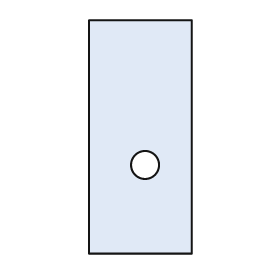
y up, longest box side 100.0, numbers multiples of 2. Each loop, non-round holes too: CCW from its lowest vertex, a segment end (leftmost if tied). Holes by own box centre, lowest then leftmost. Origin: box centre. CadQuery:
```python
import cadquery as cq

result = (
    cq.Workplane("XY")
    .moveTo(-22.0, -50.0)
    .lineTo(22.0, -50.0)
    .lineTo(22.0, 50.0)
    .lineTo(-22.0, 50.0)
    .close()
    .moveTo(2.0, -12.0)
    .circle(6.0)
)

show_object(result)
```